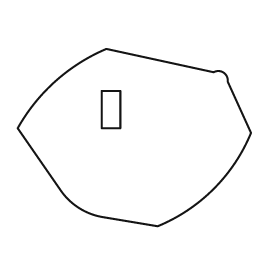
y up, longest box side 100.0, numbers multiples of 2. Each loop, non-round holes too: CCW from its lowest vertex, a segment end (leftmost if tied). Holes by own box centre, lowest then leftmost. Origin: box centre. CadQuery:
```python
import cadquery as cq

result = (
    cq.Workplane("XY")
    .moveTo(10.0, -38.0)
    .threePointArc((34.0, -22.0), (50.0, 2.0))
    .lineTo(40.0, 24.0)
    .threePointArc((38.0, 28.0), (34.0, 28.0))
    .lineTo(-12.0, 38.0)
    .threePointArc((-34.0, 24.0), (-50.0, 4.0))
    .lineTo(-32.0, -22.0)
    .threePointArc((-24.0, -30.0), (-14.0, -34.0))
    .close()
    .moveTo(-14.0, 4.0)
    .lineTo(-6.0, 4.0)
    .lineTo(-6.0, 20.0)
    .lineTo(-14.0, 20.0)
    .close()
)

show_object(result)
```